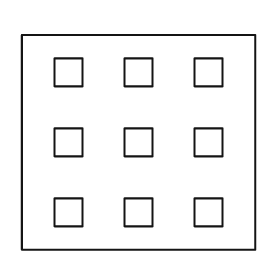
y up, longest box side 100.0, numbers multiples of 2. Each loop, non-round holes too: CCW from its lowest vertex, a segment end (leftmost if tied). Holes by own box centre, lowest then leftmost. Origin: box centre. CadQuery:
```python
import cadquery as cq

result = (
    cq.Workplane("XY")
    .moveTo(-50.0, -46.0)
    .lineTo(50.0, -46.0)
    .lineTo(50.0, 46.0)
    .lineTo(-50.0, 46.0)
    .close()
    .moveTo(-36.0, -36.0)
    .lineTo(-24.0, -36.0)
    .lineTo(-24.0, -24.0)
    .lineTo(-36.0, -24.0)
    .close()
    .moveTo(-6.0, -36.0)
    .lineTo(6.0, -36.0)
    .lineTo(6.0, -24.0)
    .lineTo(-6.0, -24.0)
    .close()
    .moveTo(24.0, -36.0)
    .lineTo(36.0, -36.0)
    .lineTo(36.0, -24.0)
    .lineTo(24.0, -24.0)
    .close()
    .moveTo(-36.0, -6.0)
    .lineTo(-24.0, -6.0)
    .lineTo(-24.0, 6.0)
    .lineTo(-36.0, 6.0)
    .close()
    .moveTo(-6.0, -6.0)
    .lineTo(6.0, -6.0)
    .lineTo(6.0, 6.0)
    .lineTo(-6.0, 6.0)
    .close()
    .moveTo(24.0, -6.0)
    .lineTo(36.0, -6.0)
    .lineTo(36.0, 6.0)
    .lineTo(24.0, 6.0)
    .close()
    .moveTo(-36.0, 24.0)
    .lineTo(-24.0, 24.0)
    .lineTo(-24.0, 36.0)
    .lineTo(-36.0, 36.0)
    .close()
    .moveTo(-6.0, 24.0)
    .lineTo(6.0, 24.0)
    .lineTo(6.0, 36.0)
    .lineTo(-6.0, 36.0)
    .close()
    .moveTo(24.0, 24.0)
    .lineTo(36.0, 24.0)
    .lineTo(36.0, 36.0)
    .lineTo(24.0, 36.0)
    .close()
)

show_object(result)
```